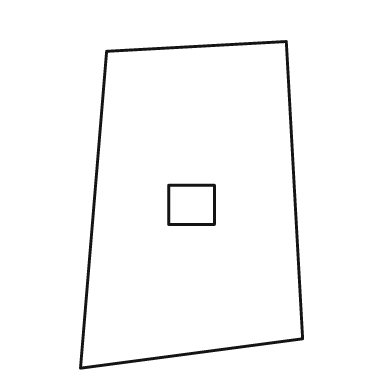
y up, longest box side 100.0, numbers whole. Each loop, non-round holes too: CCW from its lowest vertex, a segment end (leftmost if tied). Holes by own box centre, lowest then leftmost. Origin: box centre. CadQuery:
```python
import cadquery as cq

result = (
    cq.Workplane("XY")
    .moveTo(-34.0, -50.0)
    .lineTo(34.0, -41.0)
    .lineTo(29.0, 50.0)
    .lineTo(-26.0, 47.0)
    .close()
    .moveTo(-7.0, -6.0)
    .lineTo(7.0, -6.0)
    .lineTo(7.0, 6.0)
    .lineTo(-7.0, 6.0)
    .close()
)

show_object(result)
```